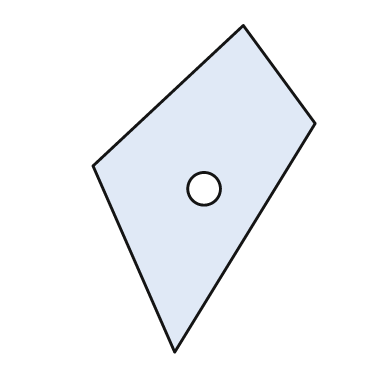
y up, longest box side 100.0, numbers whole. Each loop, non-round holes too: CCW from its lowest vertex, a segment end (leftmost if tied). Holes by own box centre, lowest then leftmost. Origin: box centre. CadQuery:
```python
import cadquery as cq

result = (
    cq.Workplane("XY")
    .moveTo(-9.0, -50.0)
    .lineTo(34.0, 20.0)
    .lineTo(12.0, 50.0)
    .lineTo(-34.0, 7.0)
    .close()
    .moveTo(0.0, 0.0)
    .circle(5.0)
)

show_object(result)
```